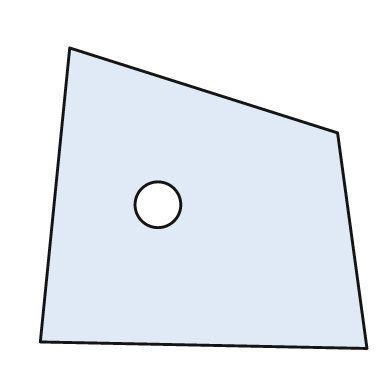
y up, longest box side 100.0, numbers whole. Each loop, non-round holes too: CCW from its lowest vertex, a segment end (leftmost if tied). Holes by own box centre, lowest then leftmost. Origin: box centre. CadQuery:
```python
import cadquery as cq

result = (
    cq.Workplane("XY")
    .moveTo(50.0, -46.0)
    .lineTo(41.0, 20.0)
    .lineTo(-41.0, 46.0)
    .lineTo(-50.0, -44.0)
    .close()
    .moveTo(-14.0, -2.0)
    .circle(7.0)
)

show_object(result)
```